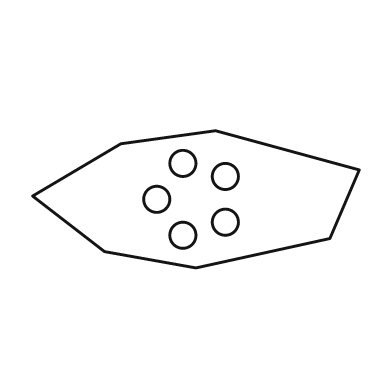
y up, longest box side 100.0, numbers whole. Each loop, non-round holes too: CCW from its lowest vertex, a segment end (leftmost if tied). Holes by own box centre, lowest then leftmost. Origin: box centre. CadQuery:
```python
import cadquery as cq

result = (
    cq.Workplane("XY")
    .moveTo(0.0, -21.0)
    .lineTo(41.0, -12.0)
    .lineTo(50.0, 9.0)
    .lineTo(6.0, 21.0)
    .lineTo(-23.0, 17.0)
    .lineTo(-50.0, 1.0)
    .lineTo(-28.0, -16.0)
    .close()
    .moveTo(-4.0, -11.0)
    .circle(4.0)
    .moveTo(9.0, -7.0)
    .circle(4.0)
    .moveTo(-12.0, 0.0)
    .circle(4.0)
    .moveTo(9.0, 7.0)
    .circle(4.0)
    .moveTo(-4.0, 11.0)
    .circle(4.0)
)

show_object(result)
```